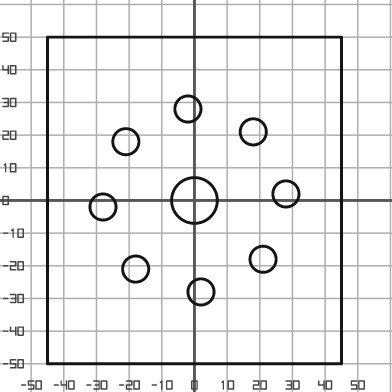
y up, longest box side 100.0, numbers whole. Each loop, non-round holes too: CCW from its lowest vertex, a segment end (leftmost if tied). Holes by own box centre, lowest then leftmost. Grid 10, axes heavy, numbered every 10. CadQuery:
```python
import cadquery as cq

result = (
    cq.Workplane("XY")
    .moveTo(-45.0, -50.0)
    .lineTo(45.0, -50.0)
    .lineTo(45.0, 50.0)
    .lineTo(-45.0, 50.0)
    .close()
    .moveTo(2.0, -28.0)
    .circle(4.0)
    .moveTo(-18.0, -21.0)
    .circle(4.0)
    .moveTo(21.0, -18.0)
    .circle(4.0)
    .moveTo(-28.0, -2.0)
    .circle(4.0)
    .moveTo(0.0, 0.0)
    .circle(7.0)
    .moveTo(28.0, 2.0)
    .circle(4.0)
    .moveTo(-21.0, 18.0)
    .circle(4.0)
    .moveTo(18.0, 21.0)
    .circle(4.0)
    .moveTo(-2.0, 28.0)
    .circle(4.0)
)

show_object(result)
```